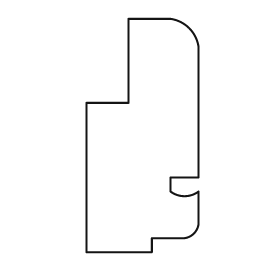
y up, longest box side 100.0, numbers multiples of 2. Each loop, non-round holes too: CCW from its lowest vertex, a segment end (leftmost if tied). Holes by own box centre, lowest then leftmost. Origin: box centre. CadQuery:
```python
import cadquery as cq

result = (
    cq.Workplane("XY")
    .moveTo(-24.0, -50.0)
    .lineTo(4.0, -50.0)
    .lineTo(4.0, -44.0)
    .lineTo(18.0, -44.0)
    .threePointArc((22.0, -42.0), (24.0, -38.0))
    .lineTo(24.0, -24.0)
    .threePointArc((18.0, -26.0), (12.0, -24.0))
    .lineTo(12.0, -18.0)
    .lineTo(24.0, -18.0)
    .lineTo(24.0, 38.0)
    .threePointArc((20.0, 46.0), (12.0, 50.0))
    .lineTo(-6.0, 50.0)
    .lineTo(-6.0, 14.0)
    .lineTo(-24.0, 14.0)
    .close()
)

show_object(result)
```